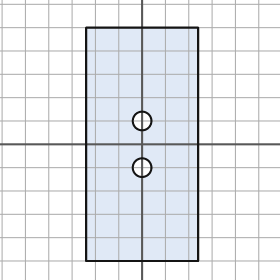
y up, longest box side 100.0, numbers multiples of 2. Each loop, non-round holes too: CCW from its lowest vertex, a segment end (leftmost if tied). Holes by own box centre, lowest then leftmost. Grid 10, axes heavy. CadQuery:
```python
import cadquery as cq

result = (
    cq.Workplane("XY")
    .moveTo(-24.0, -50.0)
    .lineTo(24.0, -50.0)
    .lineTo(24.0, 50.0)
    .lineTo(-24.0, 50.0)
    .close()
    .moveTo(0.0, -10.0)
    .circle(4.0)
    .moveTo(0.0, 10.0)
    .circle(4.0)
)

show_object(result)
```